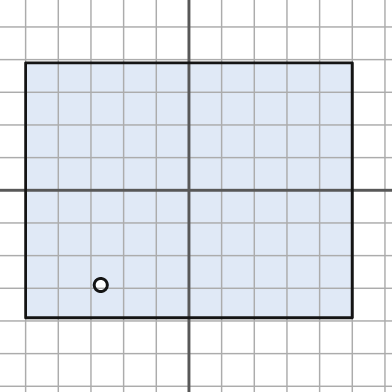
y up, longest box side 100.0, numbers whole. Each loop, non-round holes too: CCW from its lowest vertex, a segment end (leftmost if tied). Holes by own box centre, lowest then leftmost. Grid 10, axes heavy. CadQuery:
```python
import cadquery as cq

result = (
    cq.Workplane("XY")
    .moveTo(-50.0, -39.0)
    .lineTo(50.0, -39.0)
    .lineTo(50.0, 39.0)
    .lineTo(-50.0, 39.0)
    .close()
    .moveTo(-27.0, -29.0)
    .circle(2.0)
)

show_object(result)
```